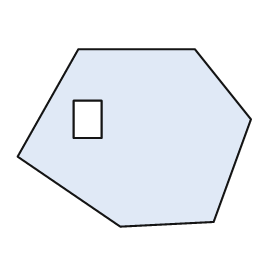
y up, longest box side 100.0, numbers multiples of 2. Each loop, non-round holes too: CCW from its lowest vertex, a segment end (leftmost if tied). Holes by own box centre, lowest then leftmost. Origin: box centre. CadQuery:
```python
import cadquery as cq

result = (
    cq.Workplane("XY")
    .moveTo(-6.0, -38.0)
    .lineTo(34.0, -36.0)
    .lineTo(50.0, 8.0)
    .lineTo(26.0, 38.0)
    .lineTo(-24.0, 38.0)
    .lineTo(-50.0, -8.0)
    .close()
    .moveTo(-26.0, 0.0)
    .lineTo(-14.0, 0.0)
    .lineTo(-14.0, 16.0)
    .lineTo(-26.0, 16.0)
    .close()
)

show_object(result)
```